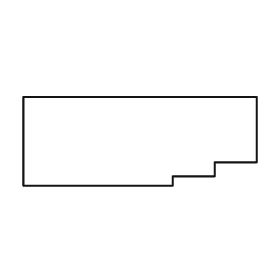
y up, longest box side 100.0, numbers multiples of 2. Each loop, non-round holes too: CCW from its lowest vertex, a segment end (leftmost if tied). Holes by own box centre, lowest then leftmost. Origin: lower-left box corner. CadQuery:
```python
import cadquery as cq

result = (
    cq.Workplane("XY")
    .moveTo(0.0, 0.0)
    .lineTo(64.0, 0.0)
    .lineTo(64.0, 4.0)
    .lineTo(82.0, 4.0)
    .lineTo(82.0, 10.0)
    .lineTo(100.0, 10.0)
    .lineTo(100.0, 38.0)
    .lineTo(0.0, 38.0)
    .close()
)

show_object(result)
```